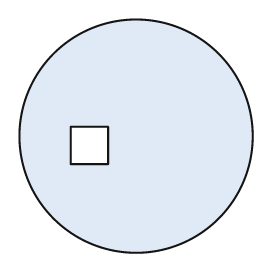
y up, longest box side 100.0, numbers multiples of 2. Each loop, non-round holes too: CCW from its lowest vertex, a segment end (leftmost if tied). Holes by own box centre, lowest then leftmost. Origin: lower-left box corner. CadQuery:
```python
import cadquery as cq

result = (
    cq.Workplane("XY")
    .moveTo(50.0, 50.0)
    .circle(50.0)
    .moveTo(22.0, 38.0)
    .lineTo(38.0, 38.0)
    .lineTo(38.0, 54.0)
    .lineTo(22.0, 54.0)
    .close()
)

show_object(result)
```